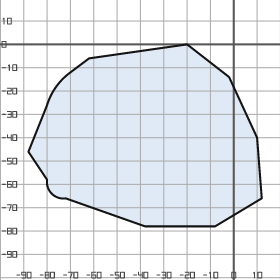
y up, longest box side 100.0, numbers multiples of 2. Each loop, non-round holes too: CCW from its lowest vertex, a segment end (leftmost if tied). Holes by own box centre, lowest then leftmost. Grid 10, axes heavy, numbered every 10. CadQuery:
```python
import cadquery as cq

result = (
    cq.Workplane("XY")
    .moveTo(-38.0, -78.0)
    .lineTo(-8.0, -78.0)
    .lineTo(12.0, -66.0)
    .lineTo(10.0, -40.0)
    .lineTo(-2.0, -14.0)
    .lineTo(-20.0, 0.0)
    .lineTo(-62.0, -6.0)
    .lineTo(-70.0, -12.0)
    .threePointArc((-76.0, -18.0), (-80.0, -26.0))
    .lineTo(-88.0, -46.0)
    .lineTo(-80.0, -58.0)
    .threePointArc((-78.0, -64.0), (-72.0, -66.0))
    .close()
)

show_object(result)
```